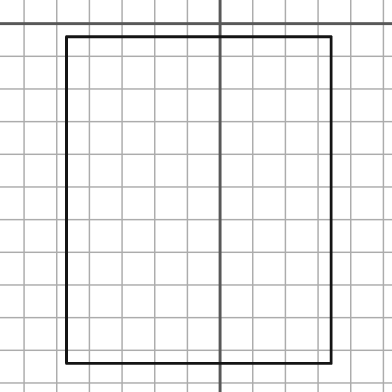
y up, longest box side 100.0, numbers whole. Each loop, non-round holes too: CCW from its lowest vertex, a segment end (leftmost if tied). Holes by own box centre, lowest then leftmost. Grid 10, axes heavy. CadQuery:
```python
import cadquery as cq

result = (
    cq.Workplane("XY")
    .moveTo(-47.0, -104.0)
    .lineTo(34.0, -104.0)
    .lineTo(34.0, -4.0)
    .lineTo(-47.0, -4.0)
    .close()
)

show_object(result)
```